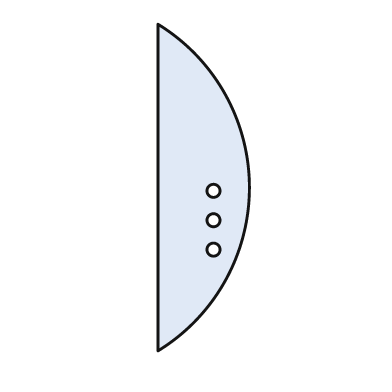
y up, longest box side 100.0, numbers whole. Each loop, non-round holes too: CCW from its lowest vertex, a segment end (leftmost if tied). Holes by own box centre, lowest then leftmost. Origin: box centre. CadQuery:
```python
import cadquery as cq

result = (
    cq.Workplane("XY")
    .moveTo(-14.0, -50.0)
    .threePointArc((14.0, 0.0), (-14.0, 50.0))
    .close()
    .moveTo(3.0, -19.0)
    .circle(2.0)
    .moveTo(3.0, -10.0)
    .circle(2.0)
    .moveTo(3.0, -1.0)
    .circle(2.0)
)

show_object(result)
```